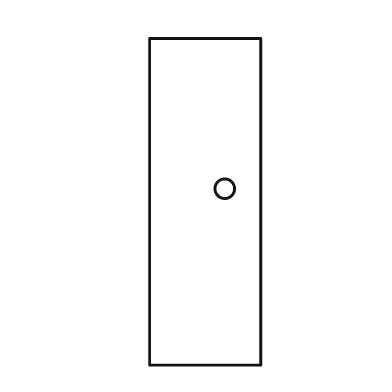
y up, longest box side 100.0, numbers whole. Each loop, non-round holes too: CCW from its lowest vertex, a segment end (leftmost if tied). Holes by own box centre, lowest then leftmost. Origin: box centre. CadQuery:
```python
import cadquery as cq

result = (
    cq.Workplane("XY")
    .moveTo(-17.0, -50.0)
    .lineTo(17.0, -50.0)
    .lineTo(17.0, 50.0)
    .lineTo(-17.0, 50.0)
    .close()
    .moveTo(6.0, 4.0)
    .circle(3.0)
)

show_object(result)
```